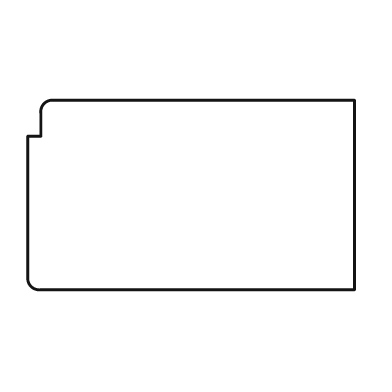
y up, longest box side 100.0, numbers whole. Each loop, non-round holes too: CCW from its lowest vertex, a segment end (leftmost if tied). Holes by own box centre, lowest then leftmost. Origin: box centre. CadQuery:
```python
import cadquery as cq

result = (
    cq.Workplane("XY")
    .moveTo(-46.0, -29.0)
    .lineTo(50.0, -29.0)
    .lineTo(50.0, 29.0)
    .lineTo(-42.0, 29.0)
    .threePointArc((-45.0, 28.0), (-46.0, 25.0))
    .lineTo(-46.0, 18.0)
    .lineTo(-50.0, 18.0)
    .lineTo(-50.0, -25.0)
    .threePointArc((-49.0, -28.0), (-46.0, -29.0))
    .close()
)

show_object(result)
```